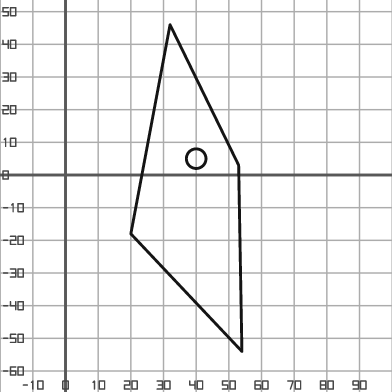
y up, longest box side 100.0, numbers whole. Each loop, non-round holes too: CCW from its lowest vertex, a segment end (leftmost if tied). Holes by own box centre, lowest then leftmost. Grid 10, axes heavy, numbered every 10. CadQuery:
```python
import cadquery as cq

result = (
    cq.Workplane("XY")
    .moveTo(54.0, -54.0)
    .lineTo(53.0, 3.0)
    .lineTo(32.0, 46.0)
    .lineTo(20.0, -18.0)
    .close()
    .moveTo(40.0, 5.0)
    .circle(3.0)
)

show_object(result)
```